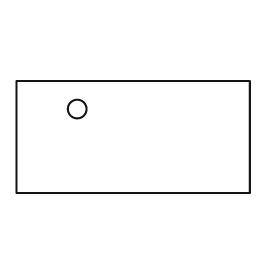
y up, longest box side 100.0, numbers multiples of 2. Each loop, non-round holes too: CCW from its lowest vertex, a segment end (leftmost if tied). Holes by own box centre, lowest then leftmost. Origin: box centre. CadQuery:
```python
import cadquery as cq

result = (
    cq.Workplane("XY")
    .moveTo(-50.0, -24.0)
    .lineTo(50.0, -24.0)
    .lineTo(50.0, 24.0)
    .lineTo(-50.0, 24.0)
    .close()
    .moveTo(-24.0, 12.0)
    .circle(4.0)
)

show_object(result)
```